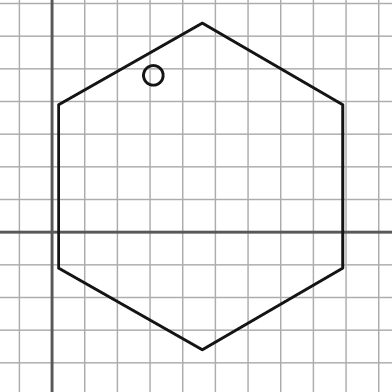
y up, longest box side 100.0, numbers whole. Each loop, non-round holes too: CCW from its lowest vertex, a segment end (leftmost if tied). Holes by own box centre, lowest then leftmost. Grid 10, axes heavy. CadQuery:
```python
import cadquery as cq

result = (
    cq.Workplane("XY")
    .moveTo(46.0, -36.0)
    .lineTo(89.0, -11.0)
    .lineTo(89.0, 39.0)
    .lineTo(46.0, 64.0)
    .lineTo(2.0, 39.0)
    .lineTo(2.0, -11.0)
    .close()
    .moveTo(31.0, 48.0)
    .circle(3.0)
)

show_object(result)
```